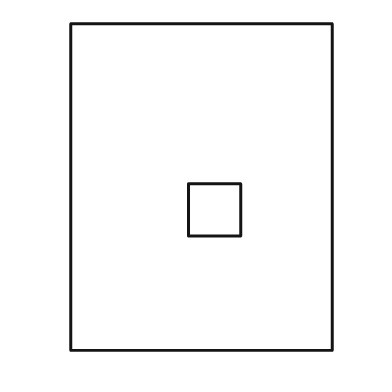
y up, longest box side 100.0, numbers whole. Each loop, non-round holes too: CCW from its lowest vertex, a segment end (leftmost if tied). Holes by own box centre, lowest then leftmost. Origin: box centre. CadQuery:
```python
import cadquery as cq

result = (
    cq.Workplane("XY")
    .moveTo(-40.0, -50.0)
    .lineTo(40.0, -50.0)
    .lineTo(40.0, 50.0)
    .lineTo(-40.0, 50.0)
    .close()
    .moveTo(-4.0, -15.0)
    .lineTo(12.0, -15.0)
    .lineTo(12.0, 1.0)
    .lineTo(-4.0, 1.0)
    .close()
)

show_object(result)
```